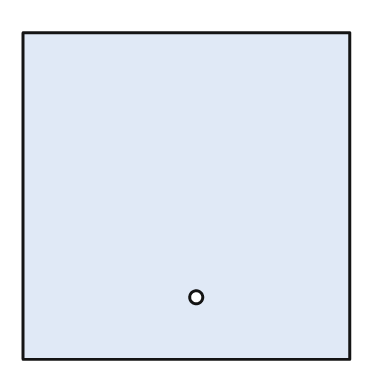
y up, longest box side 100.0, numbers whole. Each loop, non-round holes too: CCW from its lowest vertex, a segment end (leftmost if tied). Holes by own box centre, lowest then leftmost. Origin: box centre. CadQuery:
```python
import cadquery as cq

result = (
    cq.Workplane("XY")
    .moveTo(-50.0, -50.0)
    .lineTo(50.0, -50.0)
    .lineTo(50.0, 50.0)
    .lineTo(-50.0, 50.0)
    .close()
    .moveTo(3.0, -31.0)
    .circle(2.0)
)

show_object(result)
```